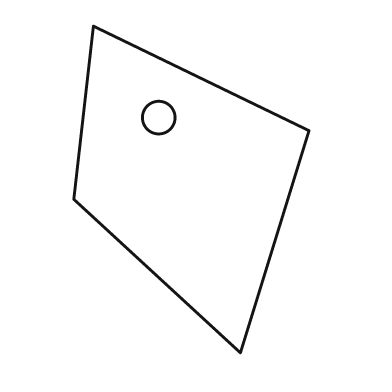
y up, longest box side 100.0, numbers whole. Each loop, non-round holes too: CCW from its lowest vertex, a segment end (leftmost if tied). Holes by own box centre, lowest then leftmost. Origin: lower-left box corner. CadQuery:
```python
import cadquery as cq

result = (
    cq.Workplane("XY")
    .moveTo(51.0, 0.0)
    .lineTo(72.0, 68.0)
    .lineTo(6.0, 100.0)
    .lineTo(0.0, 47.0)
    .close()
    .moveTo(26.0, 72.0)
    .circle(5.0)
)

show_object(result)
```